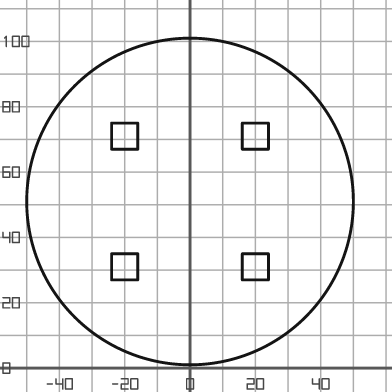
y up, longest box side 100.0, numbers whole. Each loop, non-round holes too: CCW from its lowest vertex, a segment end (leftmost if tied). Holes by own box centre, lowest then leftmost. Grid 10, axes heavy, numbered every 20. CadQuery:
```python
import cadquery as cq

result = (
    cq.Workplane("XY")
    .moveTo(0.0, 51.0)
    .circle(50.0)
    .moveTo(-24.0, 27.0)
    .lineTo(-16.0, 27.0)
    .lineTo(-16.0, 35.0)
    .lineTo(-24.0, 35.0)
    .close()
    .moveTo(16.0, 27.0)
    .lineTo(24.0, 27.0)
    .lineTo(24.0, 35.0)
    .lineTo(16.0, 35.0)
    .close()
    .moveTo(-24.0, 67.0)
    .lineTo(-16.0, 67.0)
    .lineTo(-16.0, 75.0)
    .lineTo(-24.0, 75.0)
    .close()
    .moveTo(16.0, 67.0)
    .lineTo(24.0, 67.0)
    .lineTo(24.0, 75.0)
    .lineTo(16.0, 75.0)
    .close()
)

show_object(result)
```